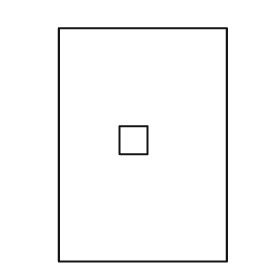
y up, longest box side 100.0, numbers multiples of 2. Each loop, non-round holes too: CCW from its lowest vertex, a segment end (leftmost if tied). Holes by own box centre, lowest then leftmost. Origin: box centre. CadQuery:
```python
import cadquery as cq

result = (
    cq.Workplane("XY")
    .moveTo(-36.0, -50.0)
    .lineTo(36.0, -50.0)
    .lineTo(36.0, 50.0)
    .lineTo(-36.0, 50.0)
    .close()
    .moveTo(-10.0, -4.0)
    .lineTo(2.0, -4.0)
    .lineTo(2.0, 8.0)
    .lineTo(-10.0, 8.0)
    .close()
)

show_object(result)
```